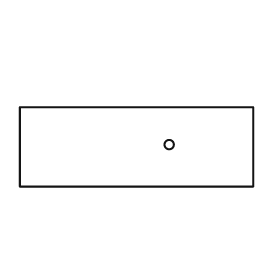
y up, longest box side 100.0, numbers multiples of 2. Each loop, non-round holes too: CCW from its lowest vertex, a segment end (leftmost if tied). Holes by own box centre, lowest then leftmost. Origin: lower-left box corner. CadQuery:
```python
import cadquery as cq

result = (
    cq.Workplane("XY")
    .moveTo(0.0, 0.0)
    .lineTo(100.0, 0.0)
    .lineTo(100.0, 34.0)
    .lineTo(0.0, 34.0)
    .close()
    .moveTo(64.0, 18.0)
    .circle(2.0)
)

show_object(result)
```